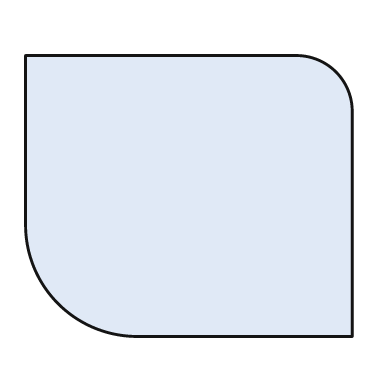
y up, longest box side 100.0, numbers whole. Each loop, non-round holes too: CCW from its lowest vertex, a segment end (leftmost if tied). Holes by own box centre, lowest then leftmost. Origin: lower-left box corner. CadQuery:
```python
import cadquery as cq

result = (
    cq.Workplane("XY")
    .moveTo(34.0, 0.0)
    .lineTo(100.0, 0.0)
    .lineTo(100.0, 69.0)
    .threePointArc((95.0, 81.0), (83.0, 86.0))
    .lineTo(0.0, 86.0)
    .lineTo(0.0, 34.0)
    .threePointArc((10.0, 10.0), (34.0, 0.0))
    .close()
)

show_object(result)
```